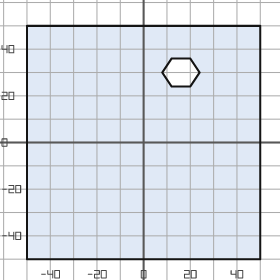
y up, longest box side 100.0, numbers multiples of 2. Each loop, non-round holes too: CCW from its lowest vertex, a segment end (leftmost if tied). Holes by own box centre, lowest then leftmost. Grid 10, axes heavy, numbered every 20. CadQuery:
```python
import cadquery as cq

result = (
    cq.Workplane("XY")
    .moveTo(-50.0, -50.0)
    .lineTo(50.0, -50.0)
    .lineTo(50.0, 50.0)
    .lineTo(-50.0, 50.0)
    .close()
    .moveTo(12.0, 24.0)
    .lineTo(20.0, 24.0)
    .lineTo(24.0, 30.0)
    .lineTo(20.0, 36.0)
    .lineTo(12.0, 36.0)
    .lineTo(8.0, 30.0)
    .close()
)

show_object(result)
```